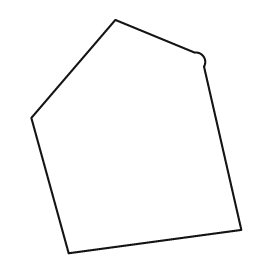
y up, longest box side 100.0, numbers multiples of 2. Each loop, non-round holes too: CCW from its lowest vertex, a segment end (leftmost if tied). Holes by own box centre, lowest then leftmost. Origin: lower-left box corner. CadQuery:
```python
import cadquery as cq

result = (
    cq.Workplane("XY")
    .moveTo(16.0, 0.0)
    .lineTo(90.0, 10.0)
    .lineTo(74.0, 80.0)
    .threePointArc((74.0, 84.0), (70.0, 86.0))
    .lineTo(36.0, 100.0)
    .lineTo(0.0, 58.0)
    .close()
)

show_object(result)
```